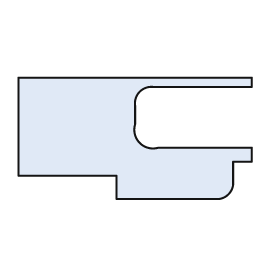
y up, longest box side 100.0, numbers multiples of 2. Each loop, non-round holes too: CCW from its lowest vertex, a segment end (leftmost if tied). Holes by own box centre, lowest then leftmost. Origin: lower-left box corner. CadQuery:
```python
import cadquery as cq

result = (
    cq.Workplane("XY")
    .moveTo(42.0, 0.0)
    .lineTo(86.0, 0.0)
    .threePointArc((90.0, 2.0), (92.0, 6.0))
    .lineTo(92.0, 16.0)
    .lineTo(100.0, 16.0)
    .lineTo(100.0, 22.0)
    .lineTo(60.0, 22.0)
    .threePointArc((52.0, 24.0), (50.0, 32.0))
    .lineTo(50.0, 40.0)
    .threePointArc((52.0, 46.0), (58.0, 48.0))
    .lineTo(100.0, 48.0)
    .lineTo(100.0, 52.0)
    .lineTo(0.0, 52.0)
    .lineTo(0.0, 10.0)
    .lineTo(42.0, 10.0)
    .close()
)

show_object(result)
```